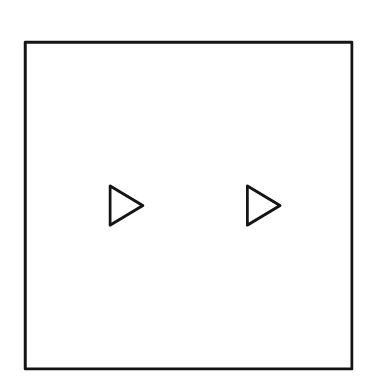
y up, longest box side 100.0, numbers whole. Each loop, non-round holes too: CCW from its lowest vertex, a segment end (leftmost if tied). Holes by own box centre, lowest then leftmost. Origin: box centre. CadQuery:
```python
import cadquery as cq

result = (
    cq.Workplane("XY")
    .moveTo(-50.0, -50.0)
    .lineTo(50.0, -50.0)
    .lineTo(50.0, 50.0)
    .lineTo(-50.0, 50.0)
    .close()
    .moveTo(-24.0, -6.0)
    .lineTo(-14.0, 0.0)
    .lineTo(-24.0, 6.0)
    .close()
    .moveTo(18.0, -6.0)
    .lineTo(28.0, 0.0)
    .lineTo(18.0, 6.0)
    .close()
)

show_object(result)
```